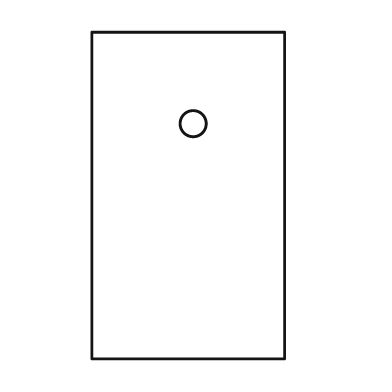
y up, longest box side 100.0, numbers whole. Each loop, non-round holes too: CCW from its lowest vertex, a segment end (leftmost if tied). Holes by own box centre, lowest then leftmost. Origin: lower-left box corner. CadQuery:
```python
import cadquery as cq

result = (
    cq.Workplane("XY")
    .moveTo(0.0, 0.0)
    .lineTo(59.0, 0.0)
    .lineTo(59.0, 100.0)
    .lineTo(0.0, 100.0)
    .close()
    .moveTo(31.0, 72.0)
    .circle(4.0)
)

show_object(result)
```